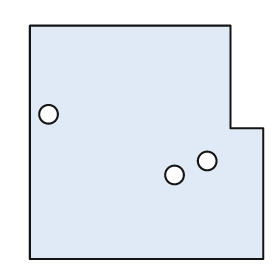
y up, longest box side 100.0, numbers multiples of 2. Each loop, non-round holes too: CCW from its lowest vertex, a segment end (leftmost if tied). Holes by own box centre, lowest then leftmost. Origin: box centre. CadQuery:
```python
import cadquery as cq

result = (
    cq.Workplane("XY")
    .moveTo(-50.0, -50.0)
    .lineTo(50.0, -50.0)
    .lineTo(50.0, 6.0)
    .lineTo(36.0, 6.0)
    .lineTo(36.0, 50.0)
    .lineTo(-50.0, 50.0)
    .close()
    .moveTo(12.0, -14.0)
    .circle(4.0)
    .moveTo(26.0, -8.0)
    .circle(4.0)
    .moveTo(-42.0, 12.0)
    .circle(4.0)
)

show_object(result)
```